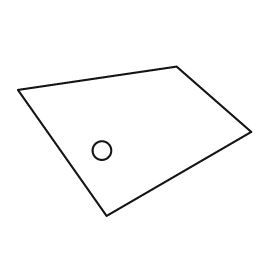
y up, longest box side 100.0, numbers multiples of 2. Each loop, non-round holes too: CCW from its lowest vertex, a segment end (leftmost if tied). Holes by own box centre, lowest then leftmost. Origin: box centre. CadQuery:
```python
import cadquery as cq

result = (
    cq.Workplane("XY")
    .moveTo(-12.0, -32.0)
    .lineTo(50.0, 4.0)
    .lineTo(18.0, 32.0)
    .lineTo(-50.0, 22.0)
    .close()
    .moveTo(-14.0, -4.0)
    .circle(4.0)
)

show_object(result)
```